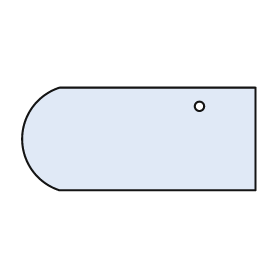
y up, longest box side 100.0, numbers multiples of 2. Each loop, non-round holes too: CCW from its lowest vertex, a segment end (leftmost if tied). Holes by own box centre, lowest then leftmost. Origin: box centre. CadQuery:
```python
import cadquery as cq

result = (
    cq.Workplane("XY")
    .moveTo(-34.0, -22.0)
    .lineTo(50.0, -22.0)
    .lineTo(50.0, 22.0)
    .lineTo(-34.0, 22.0)
    .threePointArc((-50.0, 0.0), (-34.0, -22.0))
    .close()
    .moveTo(26.0, 14.0)
    .circle(2.0)
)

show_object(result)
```